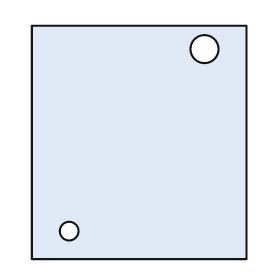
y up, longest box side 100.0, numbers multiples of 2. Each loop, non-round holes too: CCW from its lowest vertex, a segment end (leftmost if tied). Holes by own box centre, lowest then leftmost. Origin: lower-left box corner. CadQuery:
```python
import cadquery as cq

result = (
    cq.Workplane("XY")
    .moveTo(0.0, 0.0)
    .lineTo(92.0, 0.0)
    .lineTo(92.0, 100.0)
    .lineTo(0.0, 100.0)
    .close()
    .moveTo(16.0, 12.0)
    .circle(4.0)
    .moveTo(74.0, 90.0)
    .circle(6.0)
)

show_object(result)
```